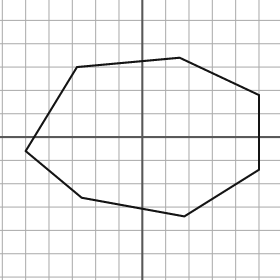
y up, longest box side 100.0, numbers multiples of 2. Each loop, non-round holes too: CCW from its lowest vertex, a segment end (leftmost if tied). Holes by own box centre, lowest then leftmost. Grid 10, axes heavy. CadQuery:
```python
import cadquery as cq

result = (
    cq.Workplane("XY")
    .moveTo(18.0, -34.0)
    .lineTo(50.0, -14.0)
    .lineTo(50.0, 18.0)
    .lineTo(16.0, 34.0)
    .lineTo(-28.0, 30.0)
    .lineTo(-50.0, -6.0)
    .lineTo(-26.0, -26.0)
    .close()
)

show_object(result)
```